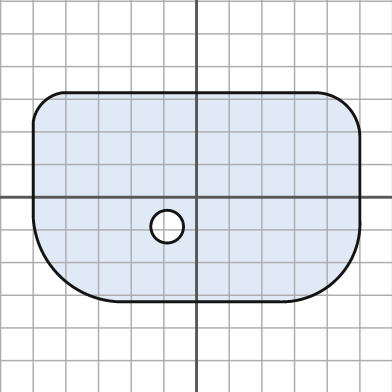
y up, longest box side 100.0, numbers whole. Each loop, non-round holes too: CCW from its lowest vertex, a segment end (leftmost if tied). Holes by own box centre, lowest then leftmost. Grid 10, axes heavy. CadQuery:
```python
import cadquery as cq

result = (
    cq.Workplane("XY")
    .moveTo(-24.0, -32.0)
    .lineTo(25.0, -32.0)
    .threePointArc((43.0, -25.0), (50.0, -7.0))
    .lineTo(50.0, 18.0)
    .threePointArc((46.0, 28.0), (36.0, 32.0))
    .lineTo(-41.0, 32.0)
    .threePointArc((-47.0, 29.0), (-50.0, 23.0))
    .lineTo(-50.0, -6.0)
    .threePointArc((-42.0, -24.0), (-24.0, -32.0))
    .close()
    .moveTo(-9.0, -9.0)
    .circle(5.0)
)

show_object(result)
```